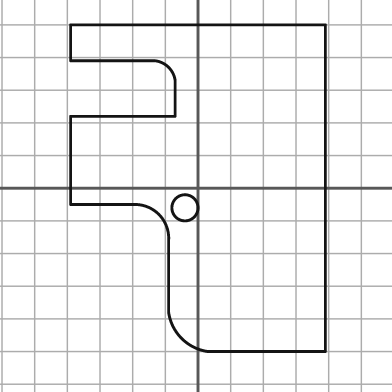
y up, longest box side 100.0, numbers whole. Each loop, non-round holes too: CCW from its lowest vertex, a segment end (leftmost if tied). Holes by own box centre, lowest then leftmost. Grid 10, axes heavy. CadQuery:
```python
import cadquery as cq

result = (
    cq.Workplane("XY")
    .moveTo(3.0, -50.0)
    .lineTo(39.0, -50.0)
    .lineTo(39.0, 50.0)
    .lineTo(-39.0, 50.0)
    .lineTo(-39.0, 39.0)
    .lineTo(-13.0, 39.0)
    .threePointArc((-9.0, 37.0), (-7.0, 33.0))
    .lineTo(-7.0, 22.0)
    .lineTo(-39.0, 22.0)
    .lineTo(-39.0, -5.0)
    .lineTo(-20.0, -5.0)
    .threePointArc((-12.0, -8.0), (-9.0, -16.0))
    .lineTo(-9.0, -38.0)
    .threePointArc((-5.0, -46.0), (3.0, -50.0))
    .close()
    .moveTo(-4.0, -6.0)
    .circle(4.0)
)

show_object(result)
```